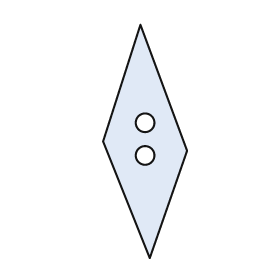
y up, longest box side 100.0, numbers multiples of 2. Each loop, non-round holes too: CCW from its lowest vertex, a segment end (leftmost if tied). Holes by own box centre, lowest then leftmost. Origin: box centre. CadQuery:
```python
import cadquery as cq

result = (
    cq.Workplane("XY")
    .moveTo(2.0, -50.0)
    .lineTo(18.0, -4.0)
    .lineTo(-2.0, 50.0)
    .lineTo(-18.0, 0.0)
    .close()
    .moveTo(0.0, -6.0)
    .circle(4.0)
    .moveTo(0.0, 8.0)
    .circle(4.0)
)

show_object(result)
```